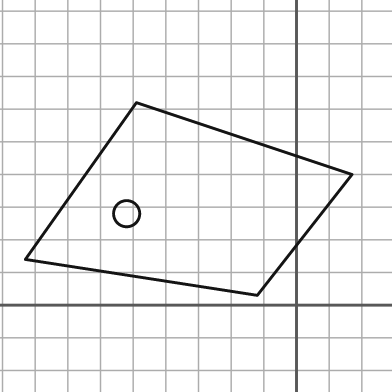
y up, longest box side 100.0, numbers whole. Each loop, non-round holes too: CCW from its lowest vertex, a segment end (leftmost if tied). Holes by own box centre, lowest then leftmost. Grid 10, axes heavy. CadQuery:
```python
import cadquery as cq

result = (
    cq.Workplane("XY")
    .moveTo(-12.0, 3.0)
    .lineTo(17.0, 40.0)
    .lineTo(-49.0, 62.0)
    .lineTo(-83.0, 14.0)
    .close()
    .moveTo(-52.0, 28.0)
    .circle(4.0)
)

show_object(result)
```